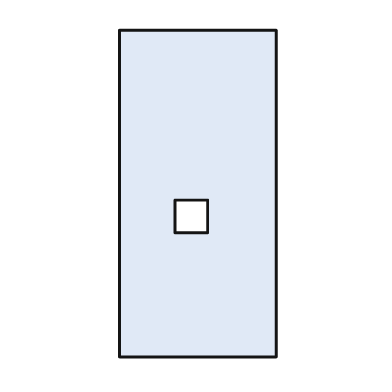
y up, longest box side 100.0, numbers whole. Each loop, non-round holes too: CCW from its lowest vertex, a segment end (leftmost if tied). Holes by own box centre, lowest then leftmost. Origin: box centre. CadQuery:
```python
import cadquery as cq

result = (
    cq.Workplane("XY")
    .moveTo(-24.0, -50.0)
    .lineTo(24.0, -50.0)
    .lineTo(24.0, 50.0)
    .lineTo(-24.0, 50.0)
    .close()
    .moveTo(-7.0, -12.0)
    .lineTo(3.0, -12.0)
    .lineTo(3.0, -2.0)
    .lineTo(-7.0, -2.0)
    .close()
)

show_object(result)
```